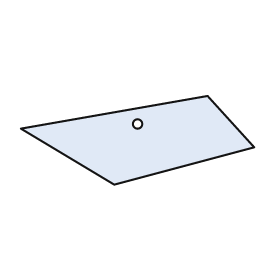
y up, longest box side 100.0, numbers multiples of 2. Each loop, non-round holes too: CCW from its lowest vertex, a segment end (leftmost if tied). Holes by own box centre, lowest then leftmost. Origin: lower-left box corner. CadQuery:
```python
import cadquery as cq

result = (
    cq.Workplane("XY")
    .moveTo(40.0, 0.0)
    .lineTo(100.0, 16.0)
    .lineTo(80.0, 38.0)
    .lineTo(0.0, 24.0)
    .close()
    .moveTo(50.0, 26.0)
    .circle(2.0)
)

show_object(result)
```